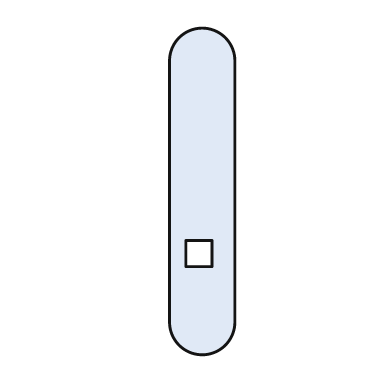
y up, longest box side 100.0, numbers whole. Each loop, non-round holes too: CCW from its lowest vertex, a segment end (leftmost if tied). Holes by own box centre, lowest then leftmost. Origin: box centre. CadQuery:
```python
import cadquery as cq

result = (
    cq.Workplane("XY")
    .moveTo(-10.0, -40.0)
    .threePointArc((0.0, -50.0), (10.0, -40.0))
    .lineTo(10.0, 40.0)
    .threePointArc((0.0, 50.0), (-10.0, 40.0))
    .close()
    .moveTo(-5.0, -23.0)
    .lineTo(3.0, -23.0)
    .lineTo(3.0, -15.0)
    .lineTo(-5.0, -15.0)
    .close()
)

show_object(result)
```